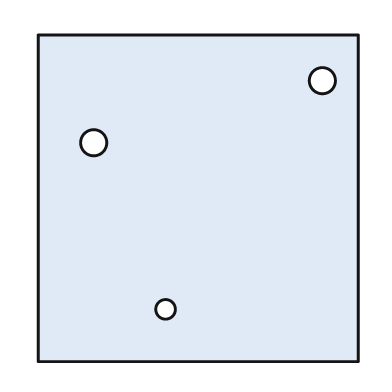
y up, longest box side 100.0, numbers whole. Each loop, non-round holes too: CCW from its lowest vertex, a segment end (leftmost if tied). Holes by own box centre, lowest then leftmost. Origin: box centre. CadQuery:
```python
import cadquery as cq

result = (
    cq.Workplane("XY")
    .moveTo(-49.0, -50.0)
    .lineTo(49.0, -50.0)
    .lineTo(49.0, 50.0)
    .lineTo(-49.0, 50.0)
    .close()
    .moveTo(-10.0, -34.0)
    .circle(3.0)
    .moveTo(-32.0, 17.0)
    .circle(4.0)
    .moveTo(38.0, 36.0)
    .circle(4.0)
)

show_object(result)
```